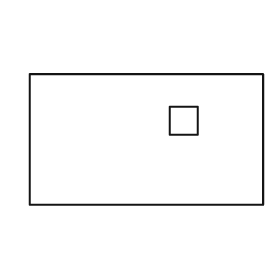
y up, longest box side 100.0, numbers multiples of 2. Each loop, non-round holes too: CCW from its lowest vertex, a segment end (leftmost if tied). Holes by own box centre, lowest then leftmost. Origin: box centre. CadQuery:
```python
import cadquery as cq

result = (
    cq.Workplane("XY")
    .moveTo(-50.0, -28.0)
    .lineTo(50.0, -28.0)
    .lineTo(50.0, 28.0)
    .lineTo(-50.0, 28.0)
    .close()
    .moveTo(10.0, 2.0)
    .lineTo(22.0, 2.0)
    .lineTo(22.0, 14.0)
    .lineTo(10.0, 14.0)
    .close()
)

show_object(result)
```